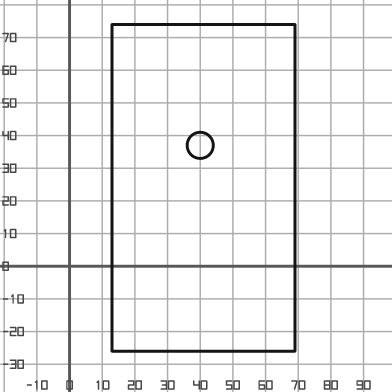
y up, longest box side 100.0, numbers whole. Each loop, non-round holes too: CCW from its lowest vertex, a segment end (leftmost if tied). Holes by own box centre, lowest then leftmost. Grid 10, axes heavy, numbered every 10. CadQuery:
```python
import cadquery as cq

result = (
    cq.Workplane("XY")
    .moveTo(13.0, -26.0)
    .lineTo(69.0, -26.0)
    .lineTo(69.0, 74.0)
    .lineTo(13.0, 74.0)
    .close()
    .moveTo(40.0, 37.0)
    .circle(4.0)
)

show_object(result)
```